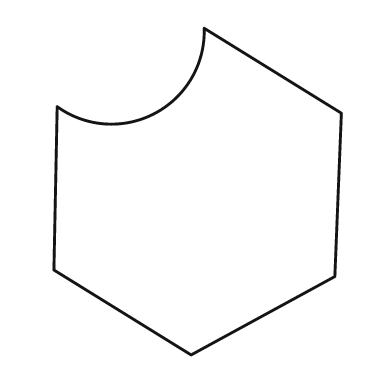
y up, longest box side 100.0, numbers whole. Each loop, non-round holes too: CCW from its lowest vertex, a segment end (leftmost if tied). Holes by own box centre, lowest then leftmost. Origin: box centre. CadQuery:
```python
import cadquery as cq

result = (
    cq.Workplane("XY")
    .moveTo(-2.0, -50.0)
    .lineTo(42.0, -26.0)
    .lineTo(44.0, 24.0)
    .lineTo(2.0, 50.0)
    .threePointArc((-13.0, 24.0), (-43.0, 26.0))
    .lineTo(-44.0, -24.0)
    .close()
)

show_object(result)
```